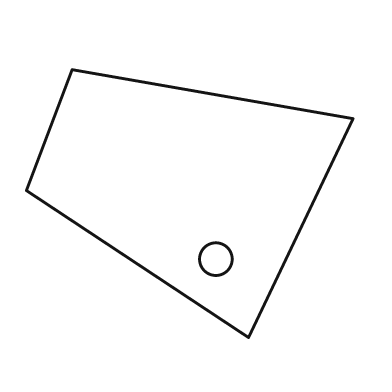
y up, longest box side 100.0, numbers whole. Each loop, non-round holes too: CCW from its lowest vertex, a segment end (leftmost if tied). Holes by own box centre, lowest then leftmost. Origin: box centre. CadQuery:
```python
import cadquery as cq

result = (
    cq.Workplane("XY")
    .moveTo(18.0, -41.0)
    .lineTo(50.0, 26.0)
    .lineTo(-36.0, 41.0)
    .lineTo(-50.0, 4.0)
    .close()
    .moveTo(8.0, -17.0)
    .circle(5.0)
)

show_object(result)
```